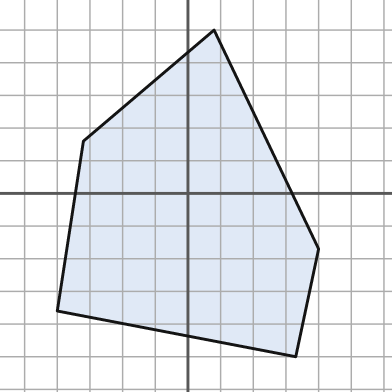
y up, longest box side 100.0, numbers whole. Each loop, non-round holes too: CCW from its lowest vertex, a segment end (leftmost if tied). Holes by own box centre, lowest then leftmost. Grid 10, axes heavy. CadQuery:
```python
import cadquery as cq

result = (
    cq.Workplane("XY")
    .moveTo(33.0, -50.0)
    .lineTo(40.0, -17.0)
    .lineTo(8.0, 50.0)
    .lineTo(-32.0, 16.0)
    .lineTo(-40.0, -36.0)
    .close()
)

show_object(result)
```